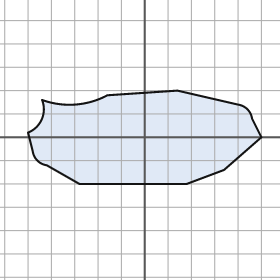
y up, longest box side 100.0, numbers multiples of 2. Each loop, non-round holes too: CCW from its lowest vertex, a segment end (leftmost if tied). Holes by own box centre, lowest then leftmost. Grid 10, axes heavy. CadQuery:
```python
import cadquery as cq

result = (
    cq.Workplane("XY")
    .moveTo(-28.0, -20.0)
    .lineTo(18.0, -20.0)
    .lineTo(34.0, -14.0)
    .lineTo(50.0, 0.0)
    .lineTo(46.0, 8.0)
    .threePointArc((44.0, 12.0), (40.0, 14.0))
    .lineTo(14.0, 20.0)
    .lineTo(-16.0, 18.0)
    .threePointArc((-30.0, 14.0), (-44.0, 16.0))
    .threePointArc((-44.0, 8.0), (-50.0, 2.0))
    .lineTo(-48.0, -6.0)
    .threePointArc((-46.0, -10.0), (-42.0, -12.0))
    .close()
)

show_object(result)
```